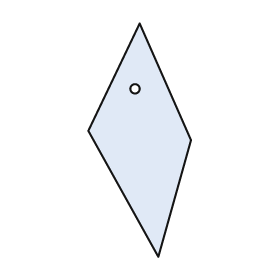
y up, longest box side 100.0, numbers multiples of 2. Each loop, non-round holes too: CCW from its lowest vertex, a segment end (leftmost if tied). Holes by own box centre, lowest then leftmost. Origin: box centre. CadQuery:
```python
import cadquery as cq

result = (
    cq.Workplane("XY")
    .moveTo(8.0, -50.0)
    .lineTo(22.0, 0.0)
    .lineTo(0.0, 50.0)
    .lineTo(-22.0, 4.0)
    .close()
    .moveTo(-2.0, 22.0)
    .circle(2.0)
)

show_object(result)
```